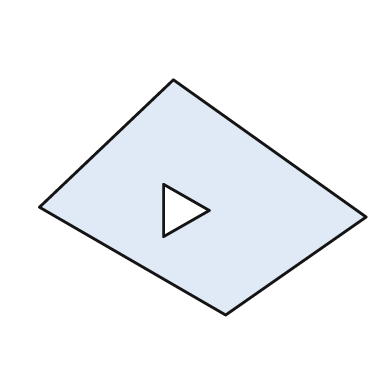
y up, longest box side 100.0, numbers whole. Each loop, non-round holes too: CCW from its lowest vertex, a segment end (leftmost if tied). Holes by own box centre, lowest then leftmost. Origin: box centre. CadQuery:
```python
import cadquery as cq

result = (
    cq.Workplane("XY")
    .moveTo(7.0, -36.0)
    .lineTo(50.0, -6.0)
    .lineTo(-9.0, 36.0)
    .lineTo(-50.0, -3.0)
    .close()
    .moveTo(-12.0, -12.0)
    .lineTo(2.0, -4.0)
    .lineTo(-12.0, 4.0)
    .close()
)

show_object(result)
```